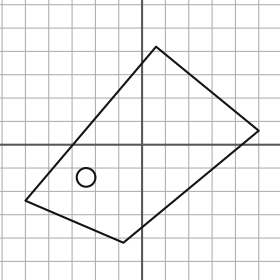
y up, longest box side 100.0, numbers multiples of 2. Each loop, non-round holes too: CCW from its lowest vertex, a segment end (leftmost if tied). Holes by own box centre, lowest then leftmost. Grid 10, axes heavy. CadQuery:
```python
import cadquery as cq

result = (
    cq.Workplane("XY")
    .moveTo(-8.0, -42.0)
    .lineTo(50.0, 6.0)
    .lineTo(6.0, 42.0)
    .lineTo(-50.0, -24.0)
    .close()
    .moveTo(-24.0, -14.0)
    .circle(4.0)
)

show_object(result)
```